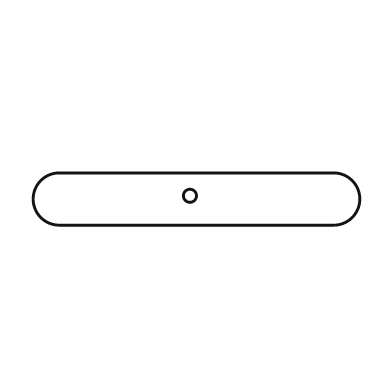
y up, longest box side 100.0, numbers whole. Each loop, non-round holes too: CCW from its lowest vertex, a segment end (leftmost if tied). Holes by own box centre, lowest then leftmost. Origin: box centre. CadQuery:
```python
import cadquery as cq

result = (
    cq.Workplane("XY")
    .moveTo(-42.0, -8.0)
    .lineTo(42.0, -8.0)
    .threePointArc((50.0, 0.0), (42.0, 8.0))
    .lineTo(-42.0, 8.0)
    .threePointArc((-50.0, 0.0), (-42.0, -8.0))
    .close()
    .moveTo(-2.0, 1.0)
    .circle(2.0)
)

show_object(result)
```